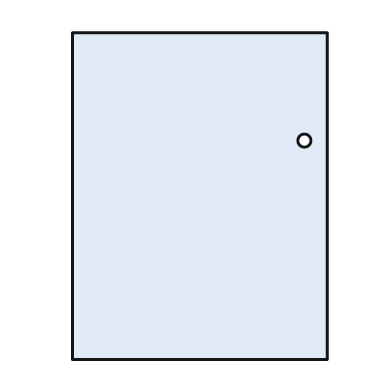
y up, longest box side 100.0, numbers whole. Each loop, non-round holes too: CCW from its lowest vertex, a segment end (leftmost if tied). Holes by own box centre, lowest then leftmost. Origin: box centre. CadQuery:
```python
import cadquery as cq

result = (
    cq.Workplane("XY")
    .moveTo(-39.0, -50.0)
    .lineTo(39.0, -50.0)
    .lineTo(39.0, 50.0)
    .lineTo(-39.0, 50.0)
    .close()
    .moveTo(32.0, 17.0)
    .circle(2.0)
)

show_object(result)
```